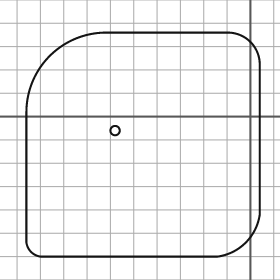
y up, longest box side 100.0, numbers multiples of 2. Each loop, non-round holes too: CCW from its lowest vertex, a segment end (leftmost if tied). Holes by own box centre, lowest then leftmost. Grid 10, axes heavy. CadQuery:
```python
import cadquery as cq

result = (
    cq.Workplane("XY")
    .moveTo(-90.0, -60.0)
    .lineTo(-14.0, -60.0)
    .threePointArc((-2.0, -54.0), (4.0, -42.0))
    .lineTo(4.0, 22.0)
    .threePointArc((0.0, 32.0), (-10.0, 36.0))
    .lineTo(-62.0, 36.0)
    .threePointArc((-86.0, 26.0), (-96.0, 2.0))
    .lineTo(-96.0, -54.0)
    .threePointArc((-94.0, -58.0), (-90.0, -60.0))
    .close()
    .moveTo(-58.0, -6.0)
    .circle(2.0)
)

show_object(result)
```